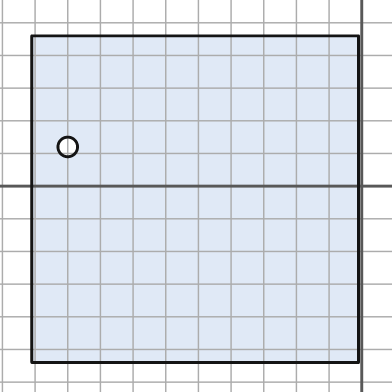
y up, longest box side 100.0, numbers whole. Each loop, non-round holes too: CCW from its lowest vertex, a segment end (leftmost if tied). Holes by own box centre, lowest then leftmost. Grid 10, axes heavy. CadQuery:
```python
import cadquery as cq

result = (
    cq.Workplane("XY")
    .moveTo(-101.0, -54.0)
    .lineTo(-1.0, -54.0)
    .lineTo(-1.0, 46.0)
    .lineTo(-101.0, 46.0)
    .close()
    .moveTo(-90.0, 12.0)
    .circle(3.0)
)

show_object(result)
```